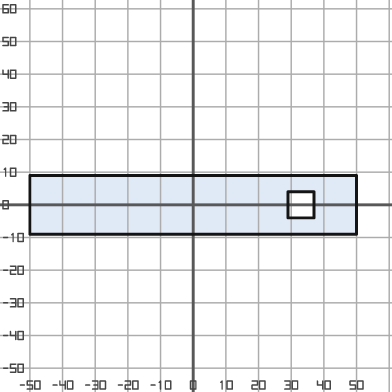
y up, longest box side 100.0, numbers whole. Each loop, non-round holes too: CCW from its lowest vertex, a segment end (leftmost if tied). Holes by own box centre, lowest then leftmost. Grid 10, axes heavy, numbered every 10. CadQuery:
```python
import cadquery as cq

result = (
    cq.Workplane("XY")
    .moveTo(-50.0, -9.0)
    .lineTo(50.0, -9.0)
    .lineTo(50.0, 9.0)
    .lineTo(-50.0, 9.0)
    .close()
    .moveTo(29.0, -4.0)
    .lineTo(37.0, -4.0)
    .lineTo(37.0, 4.0)
    .lineTo(29.0, 4.0)
    .close()
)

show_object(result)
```